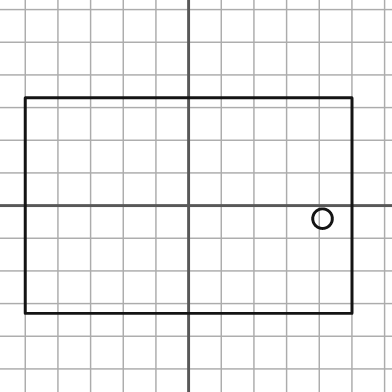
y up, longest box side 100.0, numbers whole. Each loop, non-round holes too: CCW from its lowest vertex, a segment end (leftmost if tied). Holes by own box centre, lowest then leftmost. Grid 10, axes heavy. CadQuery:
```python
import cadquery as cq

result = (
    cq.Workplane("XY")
    .moveTo(-50.0, -33.0)
    .lineTo(50.0, -33.0)
    .lineTo(50.0, 33.0)
    .lineTo(-50.0, 33.0)
    .close()
    .moveTo(41.0, -4.0)
    .circle(3.0)
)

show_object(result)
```